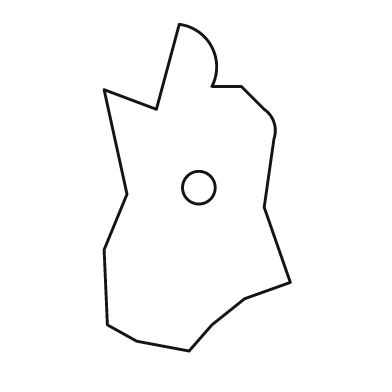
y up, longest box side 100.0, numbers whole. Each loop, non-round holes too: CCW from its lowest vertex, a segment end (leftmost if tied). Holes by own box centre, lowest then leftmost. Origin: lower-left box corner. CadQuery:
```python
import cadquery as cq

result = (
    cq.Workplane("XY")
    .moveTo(26.0, 0.0)
    .lineTo(33.0, 8.0)
    .lineTo(43.0, 16.0)
    .lineTo(57.0, 21.0)
    .lineTo(49.0, 44.0)
    .lineTo(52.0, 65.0)
    .threePointArc((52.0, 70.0), (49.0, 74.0))
    .lineTo(42.0, 81.0)
    .lineTo(33.0, 81.0)
    .threePointArc((33.0, 93.0), (23.0, 100.0))
    .lineTo(16.0, 74.0)
    .lineTo(0.0, 80.0)
    .lineTo(7.0, 48.0)
    .lineTo(0.0, 31.0)
    .lineTo(1.0, 8.0)
    .lineTo(10.0, 3.0)
    .close()
    .moveTo(29.0, 50.0)
    .circle(5.0)
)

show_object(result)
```